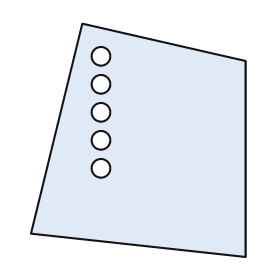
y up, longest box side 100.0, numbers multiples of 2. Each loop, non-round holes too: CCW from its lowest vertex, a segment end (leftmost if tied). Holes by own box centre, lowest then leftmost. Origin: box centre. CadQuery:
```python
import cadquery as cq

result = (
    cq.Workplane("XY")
    .moveTo(46.0, -50.0)
    .lineTo(46.0, 34.0)
    .lineTo(-24.0, 50.0)
    .lineTo(-46.0, -40.0)
    .close()
    .moveTo(-16.0, -12.0)
    .circle(4.0)
    .moveTo(-16.0, 0.0)
    .circle(4.0)
    .moveTo(-16.0, 12.0)
    .circle(4.0)
    .moveTo(-16.0, 24.0)
    .circle(4.0)
    .moveTo(-16.0, 36.0)
    .circle(4.0)
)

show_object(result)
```